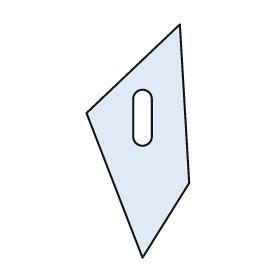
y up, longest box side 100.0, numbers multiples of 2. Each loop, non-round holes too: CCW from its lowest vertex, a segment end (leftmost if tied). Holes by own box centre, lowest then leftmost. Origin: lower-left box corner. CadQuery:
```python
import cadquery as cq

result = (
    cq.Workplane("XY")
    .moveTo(24.0, 0.0)
    .lineTo(44.0, 32.0)
    .lineTo(40.0, 100.0)
    .lineTo(0.0, 62.0)
    .close()
    .moveTo(20.0, 52.0)
    .threePointArc((24.0, 48.0), (28.0, 52.0))
    .lineTo(28.0, 68.0)
    .threePointArc((24.0, 72.0), (20.0, 68.0))
    .close()
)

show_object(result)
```